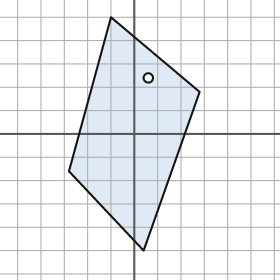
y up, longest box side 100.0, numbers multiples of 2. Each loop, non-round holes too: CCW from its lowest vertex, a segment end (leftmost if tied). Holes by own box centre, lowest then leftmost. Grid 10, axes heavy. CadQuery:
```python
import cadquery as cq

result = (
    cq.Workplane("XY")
    .moveTo(4.0, -50.0)
    .lineTo(28.0, 18.0)
    .lineTo(-10.0, 50.0)
    .lineTo(-28.0, -16.0)
    .close()
    .moveTo(6.0, 24.0)
    .circle(2.0)
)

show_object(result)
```